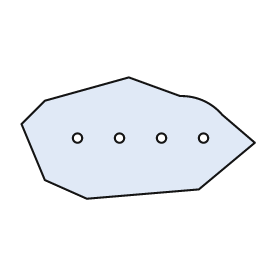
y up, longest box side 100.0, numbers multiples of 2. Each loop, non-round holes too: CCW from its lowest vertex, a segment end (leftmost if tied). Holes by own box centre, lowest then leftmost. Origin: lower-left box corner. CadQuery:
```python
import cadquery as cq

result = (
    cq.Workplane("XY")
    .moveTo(28.0, 0.0)
    .lineTo(76.0, 4.0)
    .lineTo(100.0, 24.0)
    .lineTo(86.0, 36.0)
    .threePointArc((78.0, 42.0), (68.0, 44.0))
    .lineTo(46.0, 52.0)
    .lineTo(10.0, 42.0)
    .lineTo(0.0, 32.0)
    .lineTo(10.0, 8.0)
    .close()
    .moveTo(24.0, 26.0)
    .circle(2.0)
    .moveTo(42.0, 26.0)
    .circle(2.0)
    .moveTo(60.0, 26.0)
    .circle(2.0)
    .moveTo(78.0, 26.0)
    .circle(2.0)
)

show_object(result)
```